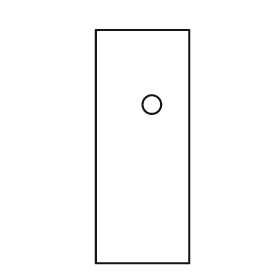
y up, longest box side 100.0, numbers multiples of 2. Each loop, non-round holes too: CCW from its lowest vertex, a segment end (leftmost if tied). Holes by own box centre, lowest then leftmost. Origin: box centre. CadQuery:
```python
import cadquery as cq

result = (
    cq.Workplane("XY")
    .moveTo(-20.0, -50.0)
    .lineTo(20.0, -50.0)
    .lineTo(20.0, 50.0)
    .lineTo(-20.0, 50.0)
    .close()
    .moveTo(4.0, 18.0)
    .circle(4.0)
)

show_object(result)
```